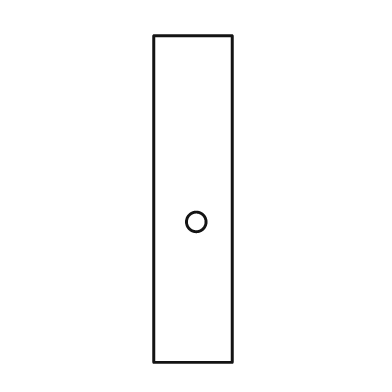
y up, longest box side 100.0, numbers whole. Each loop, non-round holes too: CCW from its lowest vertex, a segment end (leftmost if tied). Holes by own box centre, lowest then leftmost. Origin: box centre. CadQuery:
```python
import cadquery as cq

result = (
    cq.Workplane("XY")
    .moveTo(-12.0, -50.0)
    .lineTo(12.0, -50.0)
    .lineTo(12.0, 50.0)
    .lineTo(-12.0, 50.0)
    .close()
    .moveTo(1.0, -7.0)
    .circle(3.0)
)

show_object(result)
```